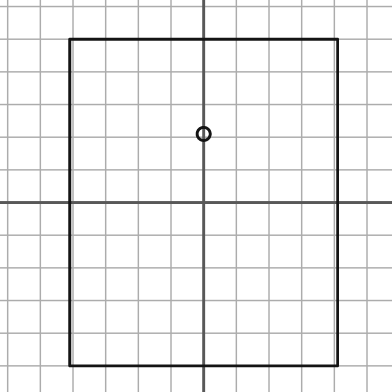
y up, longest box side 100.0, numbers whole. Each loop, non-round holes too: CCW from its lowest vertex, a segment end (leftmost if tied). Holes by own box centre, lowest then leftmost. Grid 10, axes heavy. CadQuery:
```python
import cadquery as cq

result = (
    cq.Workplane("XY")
    .moveTo(-41.0, -50.0)
    .lineTo(41.0, -50.0)
    .lineTo(41.0, 50.0)
    .lineTo(-41.0, 50.0)
    .close()
    .moveTo(0.0, 21.0)
    .circle(2.0)
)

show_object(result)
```